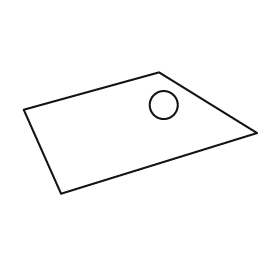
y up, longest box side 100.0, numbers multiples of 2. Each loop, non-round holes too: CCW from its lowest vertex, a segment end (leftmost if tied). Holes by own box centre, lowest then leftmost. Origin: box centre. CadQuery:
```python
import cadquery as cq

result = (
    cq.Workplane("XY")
    .moveTo(-34.0, -26.0)
    .lineTo(50.0, 0.0)
    .lineTo(8.0, 26.0)
    .lineTo(-50.0, 10.0)
    .close()
    .moveTo(10.0, 12.0)
    .circle(6.0)
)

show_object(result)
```